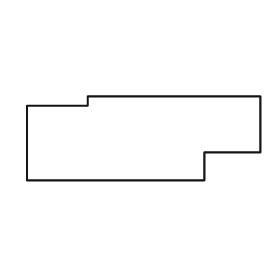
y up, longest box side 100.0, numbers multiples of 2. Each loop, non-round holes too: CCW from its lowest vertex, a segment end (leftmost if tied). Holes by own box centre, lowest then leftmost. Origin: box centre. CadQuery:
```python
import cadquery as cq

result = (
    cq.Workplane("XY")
    .moveTo(-50.0, -18.0)
    .lineTo(26.0, -18.0)
    .lineTo(26.0, -6.0)
    .lineTo(50.0, -6.0)
    .lineTo(50.0, 18.0)
    .lineTo(-24.0, 18.0)
    .lineTo(-24.0, 14.0)
    .lineTo(-50.0, 14.0)
    .close()
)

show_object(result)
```